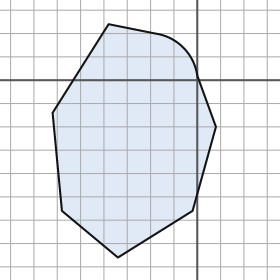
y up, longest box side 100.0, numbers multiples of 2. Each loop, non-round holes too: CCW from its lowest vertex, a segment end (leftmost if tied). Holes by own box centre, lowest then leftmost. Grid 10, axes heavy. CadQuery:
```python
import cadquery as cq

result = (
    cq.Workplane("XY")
    .moveTo(-34.0, -76.0)
    .lineTo(-2.0, -56.0)
    .lineTo(8.0, -20.0)
    .lineTo(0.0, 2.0)
    .threePointArc((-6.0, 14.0), (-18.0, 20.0))
    .lineTo(-38.0, 24.0)
    .lineTo(-62.0, -14.0)
    .lineTo(-58.0, -56.0)
    .close()
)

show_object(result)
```